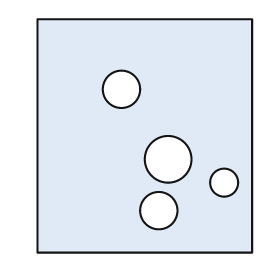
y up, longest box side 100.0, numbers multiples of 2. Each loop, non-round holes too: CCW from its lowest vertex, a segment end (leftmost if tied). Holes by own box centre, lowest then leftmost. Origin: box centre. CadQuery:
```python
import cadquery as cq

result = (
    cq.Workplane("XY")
    .moveTo(-46.0, -50.0)
    .lineTo(46.0, -50.0)
    .lineTo(46.0, 50.0)
    .lineTo(-46.0, 50.0)
    .close()
    .moveTo(6.0, -32.0)
    .circle(8.0)
    .moveTo(34.0, -20.0)
    .circle(6.0)
    .moveTo(10.0, -10.0)
    .circle(10.0)
    .moveTo(-10.0, 20.0)
    .circle(8.0)
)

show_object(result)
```